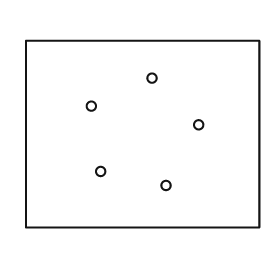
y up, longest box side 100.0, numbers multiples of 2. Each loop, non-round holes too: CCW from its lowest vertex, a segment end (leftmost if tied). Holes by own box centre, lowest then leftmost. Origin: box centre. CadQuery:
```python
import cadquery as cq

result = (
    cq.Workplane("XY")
    .moveTo(-50.0, -40.0)
    .lineTo(50.0, -40.0)
    .lineTo(50.0, 40.0)
    .lineTo(-50.0, 40.0)
    .close()
    .moveTo(10.0, -22.0)
    .circle(2.0)
    .moveTo(-18.0, -16.0)
    .circle(2.0)
    .moveTo(24.0, 4.0)
    .circle(2.0)
    .moveTo(-22.0, 12.0)
    .circle(2.0)
    .moveTo(4.0, 24.0)
    .circle(2.0)
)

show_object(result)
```